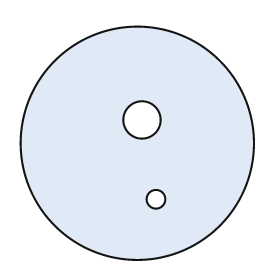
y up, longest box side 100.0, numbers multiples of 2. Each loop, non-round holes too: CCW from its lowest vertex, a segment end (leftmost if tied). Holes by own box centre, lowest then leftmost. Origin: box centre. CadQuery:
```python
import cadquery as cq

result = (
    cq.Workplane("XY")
    .moveTo(0.0, 0.0)
    .circle(50.0)
    .moveTo(8.0, -24.0)
    .circle(4.0)
    .moveTo(2.0, 10.0)
    .circle(8.0)
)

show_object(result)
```